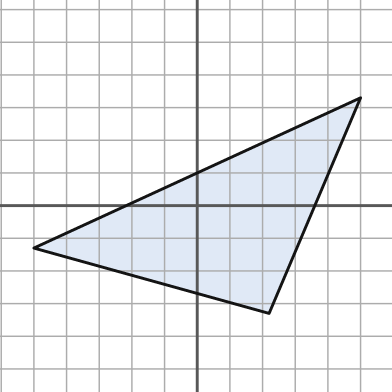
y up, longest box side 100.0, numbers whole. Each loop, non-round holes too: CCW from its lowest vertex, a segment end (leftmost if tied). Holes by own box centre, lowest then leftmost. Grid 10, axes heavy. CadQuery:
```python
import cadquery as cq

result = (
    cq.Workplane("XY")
    .moveTo(22.0, -33.0)
    .lineTo(50.0, 33.0)
    .lineTo(-50.0, -13.0)
    .close()
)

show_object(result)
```